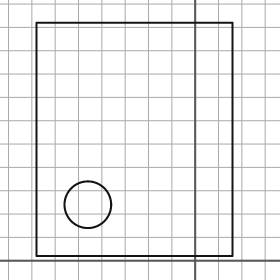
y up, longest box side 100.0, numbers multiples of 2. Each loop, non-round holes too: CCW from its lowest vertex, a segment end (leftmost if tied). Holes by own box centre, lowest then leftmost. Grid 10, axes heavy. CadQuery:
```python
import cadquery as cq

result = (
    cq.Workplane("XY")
    .moveTo(-68.0, 2.0)
    .lineTo(16.0, 2.0)
    .lineTo(16.0, 102.0)
    .lineTo(-68.0, 102.0)
    .close()
    .moveTo(-46.0, 24.0)
    .circle(10.0)
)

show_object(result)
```